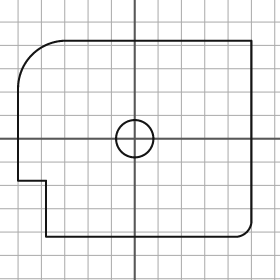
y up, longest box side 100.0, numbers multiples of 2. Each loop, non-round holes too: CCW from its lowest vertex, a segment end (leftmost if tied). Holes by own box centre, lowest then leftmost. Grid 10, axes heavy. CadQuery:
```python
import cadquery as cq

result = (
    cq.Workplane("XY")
    .moveTo(-38.0, -42.0)
    .lineTo(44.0, -42.0)
    .threePointArc((48.0, -40.0), (50.0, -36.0))
    .lineTo(50.0, 42.0)
    .lineTo(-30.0, 42.0)
    .threePointArc((-44.0, 36.0), (-50.0, 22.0))
    .lineTo(-50.0, -18.0)
    .lineTo(-38.0, -18.0)
    .close()
    .moveTo(0.0, 0.0)
    .circle(8.0)
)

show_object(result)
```